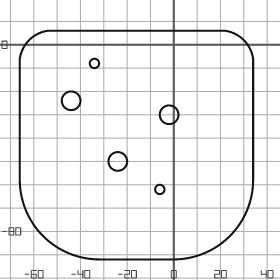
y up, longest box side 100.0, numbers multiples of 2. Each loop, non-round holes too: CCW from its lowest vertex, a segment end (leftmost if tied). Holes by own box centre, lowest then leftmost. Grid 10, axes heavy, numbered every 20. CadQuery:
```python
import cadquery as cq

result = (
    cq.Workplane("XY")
    .moveTo(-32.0, -92.0)
    .lineTo(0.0, -92.0)
    .threePointArc((24.0, -82.0), (34.0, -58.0))
    .lineTo(34.0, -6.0)
    .threePointArc((30.0, 2.0), (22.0, 6.0))
    .lineTo(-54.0, 6.0)
    .threePointArc((-62.0, 2.0), (-66.0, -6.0))
    .lineTo(-66.0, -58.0)
    .threePointArc((-56.0, -82.0), (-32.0, -92.0))
    .close()
    .moveTo(-6.0, -62.0)
    .circle(2.0)
    .moveTo(-24.0, -50.0)
    .circle(4.0)
    .moveTo(-2.0, -30.0)
    .circle(4.0)
    .moveTo(-44.0, -24.0)
    .circle(4.0)
    .moveTo(-34.0, -8.0)
    .circle(2.0)
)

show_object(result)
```